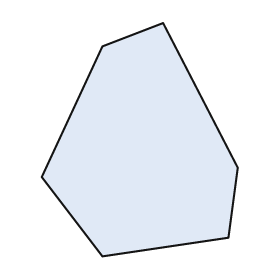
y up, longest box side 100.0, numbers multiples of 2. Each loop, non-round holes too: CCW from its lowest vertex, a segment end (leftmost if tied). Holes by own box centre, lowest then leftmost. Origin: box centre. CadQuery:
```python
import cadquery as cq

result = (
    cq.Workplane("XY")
    .moveTo(-16.0, -50.0)
    .lineTo(38.0, -42.0)
    .lineTo(42.0, -12.0)
    .lineTo(10.0, 50.0)
    .lineTo(-16.0, 40.0)
    .lineTo(-42.0, -16.0)
    .close()
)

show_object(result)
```